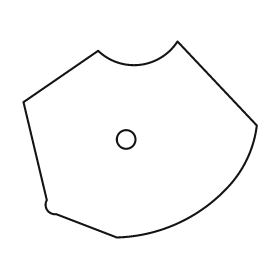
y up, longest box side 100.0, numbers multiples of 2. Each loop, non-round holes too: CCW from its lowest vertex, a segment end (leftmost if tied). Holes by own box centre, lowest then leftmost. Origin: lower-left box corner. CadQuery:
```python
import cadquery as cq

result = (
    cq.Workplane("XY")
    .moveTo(40.0, 0.0)
    .threePointArc((66.0, 6.0), (88.0, 22.0))
    .threePointArc((96.0, 34.0), (100.0, 48.0))
    .lineTo(66.0, 84.0)
    .threePointArc((50.0, 74.0), (32.0, 80.0))
    .lineTo(0.0, 58.0)
    .lineTo(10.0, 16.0)
    .threePointArc((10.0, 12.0), (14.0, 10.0))
    .close()
    .moveTo(44.0, 42.0)
    .circle(4.0)
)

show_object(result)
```